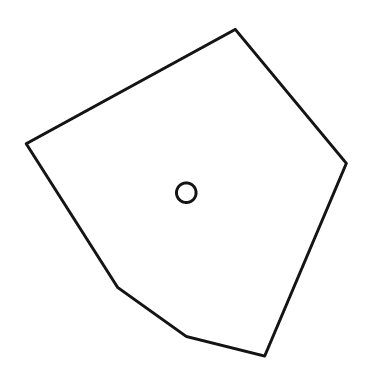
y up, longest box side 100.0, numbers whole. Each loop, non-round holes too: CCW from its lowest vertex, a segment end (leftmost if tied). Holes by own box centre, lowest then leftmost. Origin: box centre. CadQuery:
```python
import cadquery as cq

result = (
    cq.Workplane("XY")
    .moveTo(24.0, -50.0)
    .lineTo(49.0, 9.0)
    .lineTo(15.0, 50.0)
    .lineTo(-49.0, 15.0)
    .lineTo(-21.0, -29.0)
    .lineTo(0.0, -44.0)
    .close()
    .moveTo(0.0, 0.0)
    .circle(3.0)
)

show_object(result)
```